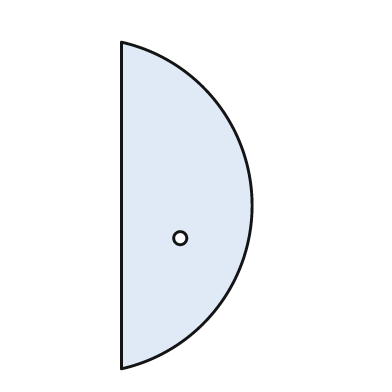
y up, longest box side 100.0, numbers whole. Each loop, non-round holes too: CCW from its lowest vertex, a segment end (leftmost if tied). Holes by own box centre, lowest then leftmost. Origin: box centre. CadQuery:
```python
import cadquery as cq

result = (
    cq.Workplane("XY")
    .moveTo(-20.0, -50.0)
    .threePointArc((20.0, 0.0), (-20.0, 50.0))
    .close()
    .moveTo(-2.0, -10.0)
    .circle(2.0)
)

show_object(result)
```